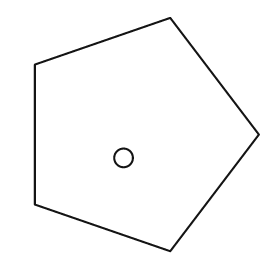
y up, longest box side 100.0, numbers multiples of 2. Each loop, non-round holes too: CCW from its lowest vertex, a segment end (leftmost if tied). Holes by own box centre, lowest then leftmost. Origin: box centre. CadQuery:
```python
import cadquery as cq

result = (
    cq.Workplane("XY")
    .moveTo(10.0, -50.0)
    .lineTo(48.0, 0.0)
    .lineTo(10.0, 50.0)
    .lineTo(-48.0, 30.0)
    .lineTo(-48.0, -30.0)
    .close()
    .moveTo(-10.0, -10.0)
    .circle(4.0)
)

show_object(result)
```